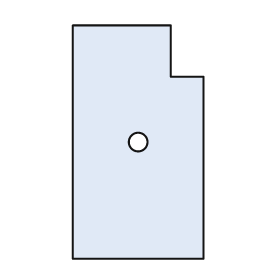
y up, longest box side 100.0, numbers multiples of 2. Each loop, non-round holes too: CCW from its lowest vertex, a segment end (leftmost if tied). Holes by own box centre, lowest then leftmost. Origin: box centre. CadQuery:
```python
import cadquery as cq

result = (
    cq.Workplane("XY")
    .moveTo(-28.0, -50.0)
    .lineTo(28.0, -50.0)
    .lineTo(28.0, 28.0)
    .lineTo(14.0, 28.0)
    .lineTo(14.0, 50.0)
    .lineTo(-28.0, 50.0)
    .close()
    .moveTo(0.0, 0.0)
    .circle(4.0)
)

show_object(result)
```